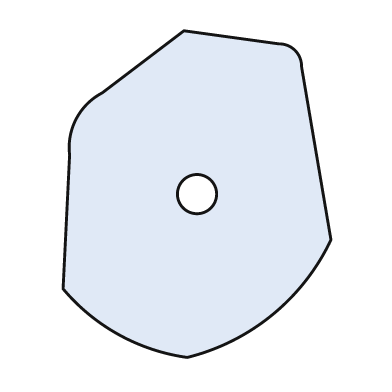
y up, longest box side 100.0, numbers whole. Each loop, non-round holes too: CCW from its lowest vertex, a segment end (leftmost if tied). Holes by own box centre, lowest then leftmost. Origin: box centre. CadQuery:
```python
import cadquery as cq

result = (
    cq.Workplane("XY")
    .moveTo(-3.0, -50.0)
    .threePointArc((23.0, -37.0), (41.0, -14.0))
    .lineTo(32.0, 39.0)
    .threePointArc((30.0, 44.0), (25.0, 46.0))
    .lineTo(-4.0, 50.0)
    .lineTo(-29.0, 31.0)
    .threePointArc((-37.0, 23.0), (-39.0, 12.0))
    .lineTo(-41.0, -29.0)
    .threePointArc((-24.0, -43.0), (-3.0, -50.0))
    .close()
    .moveTo(0.0, 0.0)
    .circle(6.0)
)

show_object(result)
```